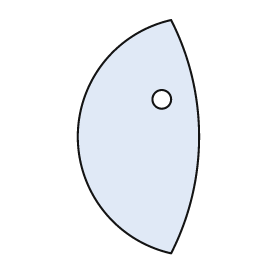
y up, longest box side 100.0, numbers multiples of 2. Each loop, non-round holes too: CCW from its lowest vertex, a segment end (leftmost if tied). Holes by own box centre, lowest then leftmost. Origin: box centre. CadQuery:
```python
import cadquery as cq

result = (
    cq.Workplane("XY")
    .moveTo(14.0, -50.0)
    .threePointArc((26.0, 0.0), (14.0, 50.0))
    .threePointArc((-26.0, 0.0), (14.0, -50.0))
    .close()
    .moveTo(10.0, 16.0)
    .circle(4.0)
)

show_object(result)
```